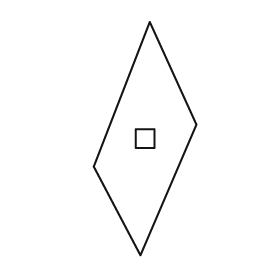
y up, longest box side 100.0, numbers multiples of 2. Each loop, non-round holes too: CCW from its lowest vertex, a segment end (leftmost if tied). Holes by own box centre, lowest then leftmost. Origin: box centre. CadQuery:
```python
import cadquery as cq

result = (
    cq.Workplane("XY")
    .moveTo(-2.0, -50.0)
    .lineTo(22.0, 6.0)
    .lineTo(2.0, 50.0)
    .lineTo(-22.0, -12.0)
    .close()
    .moveTo(-4.0, -4.0)
    .lineTo(4.0, -4.0)
    .lineTo(4.0, 4.0)
    .lineTo(-4.0, 4.0)
    .close()
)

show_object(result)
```